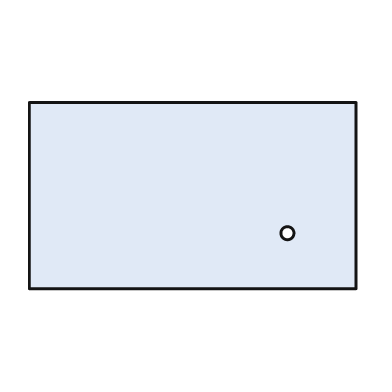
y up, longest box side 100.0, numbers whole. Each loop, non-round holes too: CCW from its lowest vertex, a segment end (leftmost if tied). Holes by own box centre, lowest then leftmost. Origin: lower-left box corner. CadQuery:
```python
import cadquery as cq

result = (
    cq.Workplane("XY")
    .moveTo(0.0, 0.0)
    .lineTo(100.0, 0.0)
    .lineTo(100.0, 57.0)
    .lineTo(0.0, 57.0)
    .close()
    .moveTo(79.0, 17.0)
    .circle(2.0)
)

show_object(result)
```